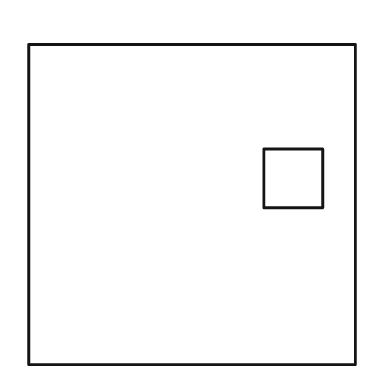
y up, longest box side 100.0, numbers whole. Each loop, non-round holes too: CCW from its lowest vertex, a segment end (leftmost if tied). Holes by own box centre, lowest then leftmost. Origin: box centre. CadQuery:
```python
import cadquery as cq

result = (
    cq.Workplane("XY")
    .moveTo(-50.0, -49.0)
    .lineTo(50.0, -49.0)
    .lineTo(50.0, 49.0)
    .lineTo(-50.0, 49.0)
    .close()
    .moveTo(22.0, -1.0)
    .lineTo(40.0, -1.0)
    .lineTo(40.0, 17.0)
    .lineTo(22.0, 17.0)
    .close()
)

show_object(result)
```